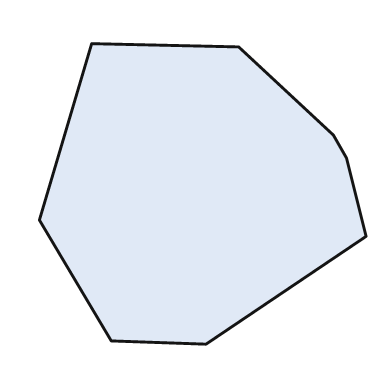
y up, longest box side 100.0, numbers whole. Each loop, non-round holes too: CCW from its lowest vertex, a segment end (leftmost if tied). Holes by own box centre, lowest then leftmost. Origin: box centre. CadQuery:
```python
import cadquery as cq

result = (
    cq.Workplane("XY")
    .moveTo(1.0, -46.0)
    .lineTo(50.0, -13.0)
    .lineTo(44.0, 11.0)
    .lineTo(40.0, 18.0)
    .lineTo(11.0, 45.0)
    .lineTo(-34.0, 46.0)
    .lineTo(-50.0, -8.0)
    .lineTo(-28.0, -45.0)
    .close()
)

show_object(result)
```